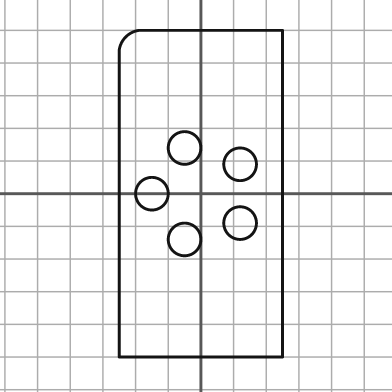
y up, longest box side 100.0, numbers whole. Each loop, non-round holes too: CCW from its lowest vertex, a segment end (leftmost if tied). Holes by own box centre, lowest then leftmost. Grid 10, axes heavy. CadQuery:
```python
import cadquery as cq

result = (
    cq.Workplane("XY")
    .moveTo(-25.0, -50.0)
    .lineTo(25.0, -50.0)
    .lineTo(25.0, 50.0)
    .lineTo(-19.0, 50.0)
    .threePointArc((-23.0, 48.0), (-25.0, 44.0))
    .close()
    .moveTo(-5.0, -14.0)
    .circle(5.0)
    .moveTo(12.0, -9.0)
    .circle(5.0)
    .moveTo(-15.0, 0.0)
    .circle(5.0)
    .moveTo(12.0, 9.0)
    .circle(5.0)
    .moveTo(-5.0, 14.0)
    .circle(5.0)
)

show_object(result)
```